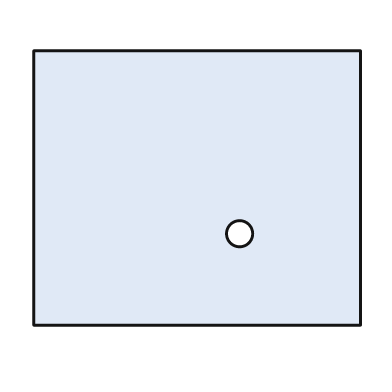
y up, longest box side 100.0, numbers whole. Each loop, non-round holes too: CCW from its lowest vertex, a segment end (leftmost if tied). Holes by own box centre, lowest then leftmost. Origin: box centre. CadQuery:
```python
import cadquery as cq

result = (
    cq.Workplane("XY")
    .moveTo(-50.0, -42.0)
    .lineTo(50.0, -42.0)
    .lineTo(50.0, 42.0)
    .lineTo(-50.0, 42.0)
    .close()
    .moveTo(13.0, -14.0)
    .circle(4.0)
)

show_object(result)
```